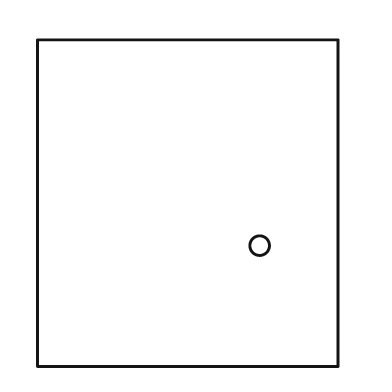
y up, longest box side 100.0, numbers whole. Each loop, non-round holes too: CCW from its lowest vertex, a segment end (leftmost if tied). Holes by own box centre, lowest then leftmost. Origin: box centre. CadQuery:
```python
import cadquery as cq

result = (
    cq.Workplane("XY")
    .moveTo(-46.0, -50.0)
    .lineTo(46.0, -50.0)
    .lineTo(46.0, 50.0)
    .lineTo(-46.0, 50.0)
    .close()
    .moveTo(22.0, -13.0)
    .circle(3.0)
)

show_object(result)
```